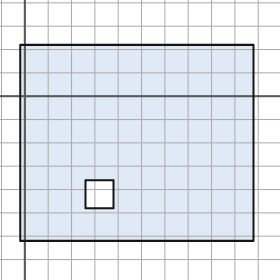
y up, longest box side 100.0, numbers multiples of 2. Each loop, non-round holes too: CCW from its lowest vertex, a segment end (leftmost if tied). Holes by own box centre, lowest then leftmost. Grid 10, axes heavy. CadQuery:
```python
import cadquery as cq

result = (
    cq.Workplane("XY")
    .moveTo(-2.0, -62.0)
    .lineTo(98.0, -62.0)
    .lineTo(98.0, 22.0)
    .lineTo(-2.0, 22.0)
    .close()
    .moveTo(26.0, -48.0)
    .lineTo(38.0, -48.0)
    .lineTo(38.0, -36.0)
    .lineTo(26.0, -36.0)
    .close()
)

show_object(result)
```